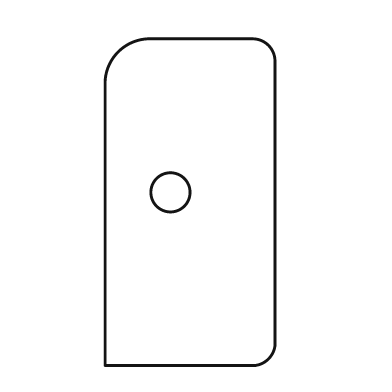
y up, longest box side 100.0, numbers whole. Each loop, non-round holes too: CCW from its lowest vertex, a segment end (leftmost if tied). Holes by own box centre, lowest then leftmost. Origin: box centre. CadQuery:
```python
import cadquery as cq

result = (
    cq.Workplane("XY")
    .moveTo(-26.0, -50.0)
    .lineTo(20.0, -50.0)
    .threePointArc((24.0, -48.0), (26.0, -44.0))
    .lineTo(26.0, 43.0)
    .threePointArc((24.0, 48.0), (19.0, 50.0))
    .lineTo(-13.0, 50.0)
    .threePointArc((-22.0, 46.0), (-26.0, 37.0))
    .close()
    .moveTo(-6.0, 3.0)
    .circle(6.0)
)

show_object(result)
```